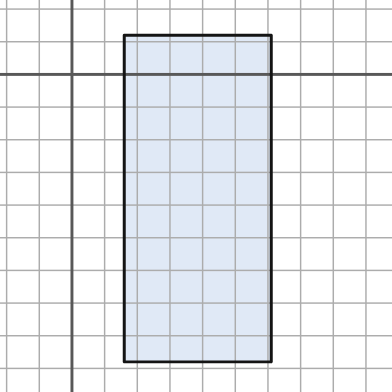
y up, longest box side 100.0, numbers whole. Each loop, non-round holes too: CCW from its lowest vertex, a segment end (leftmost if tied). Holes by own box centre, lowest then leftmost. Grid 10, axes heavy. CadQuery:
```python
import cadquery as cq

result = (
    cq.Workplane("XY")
    .moveTo(16.0, -88.0)
    .lineTo(61.0, -88.0)
    .lineTo(61.0, 12.0)
    .lineTo(16.0, 12.0)
    .close()
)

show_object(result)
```